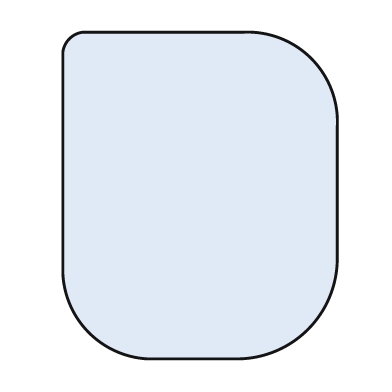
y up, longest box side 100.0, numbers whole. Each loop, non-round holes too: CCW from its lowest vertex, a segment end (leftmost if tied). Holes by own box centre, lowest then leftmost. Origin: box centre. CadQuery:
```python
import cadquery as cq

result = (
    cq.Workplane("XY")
    .moveTo(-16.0, -50.0)
    .lineTo(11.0, -50.0)
    .threePointArc((33.0, -41.0), (42.0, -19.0))
    .lineTo(42.0, 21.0)
    .threePointArc((34.0, 42.0), (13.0, 50.0))
    .lineTo(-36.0, 50.0)
    .threePointArc((-40.0, 48.0), (-42.0, 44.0))
    .lineTo(-42.0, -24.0)
    .threePointArc((-34.0, -42.0), (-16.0, -50.0))
    .close()
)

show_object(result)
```